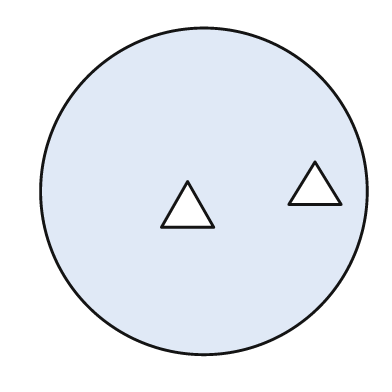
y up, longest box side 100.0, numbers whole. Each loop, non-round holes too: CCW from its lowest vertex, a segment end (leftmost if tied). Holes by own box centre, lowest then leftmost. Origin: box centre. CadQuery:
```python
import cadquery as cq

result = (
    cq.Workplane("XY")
    .moveTo(0.0, 0.0)
    .circle(50.0)
    .moveTo(-13.0, -11.0)
    .lineTo(3.0, -11.0)
    .lineTo(-5.0, 3.0)
    .close()
    .moveTo(26.0, -4.0)
    .lineTo(42.0, -4.0)
    .lineTo(34.0, 9.0)
    .close()
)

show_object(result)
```